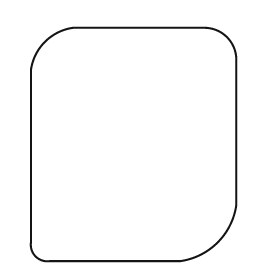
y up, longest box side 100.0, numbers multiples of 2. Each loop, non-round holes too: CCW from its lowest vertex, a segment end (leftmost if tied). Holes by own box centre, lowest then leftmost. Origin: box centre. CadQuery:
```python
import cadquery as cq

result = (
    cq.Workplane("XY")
    .moveTo(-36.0, -50.0)
    .lineTo(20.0, -50.0)
    .threePointArc((36.0, -42.0), (44.0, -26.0))
    .lineTo(44.0, 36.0)
    .threePointArc((40.0, 46.0), (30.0, 50.0))
    .lineTo(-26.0, 50.0)
    .threePointArc((-38.0, 44.0), (-44.0, 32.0))
    .lineTo(-44.0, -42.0)
    .threePointArc((-42.0, -48.0), (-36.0, -50.0))
    .close()
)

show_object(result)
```